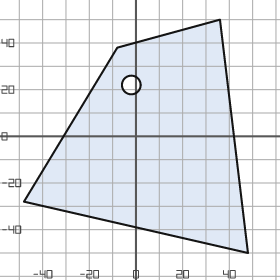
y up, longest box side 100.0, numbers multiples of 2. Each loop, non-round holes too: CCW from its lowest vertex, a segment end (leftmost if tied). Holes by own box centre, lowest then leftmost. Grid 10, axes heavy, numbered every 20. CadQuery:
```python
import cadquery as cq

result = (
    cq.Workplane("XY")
    .moveTo(48.0, -50.0)
    .lineTo(36.0, 50.0)
    .lineTo(-8.0, 38.0)
    .lineTo(-48.0, -28.0)
    .close()
    .moveTo(-2.0, 22.0)
    .circle(4.0)
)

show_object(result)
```